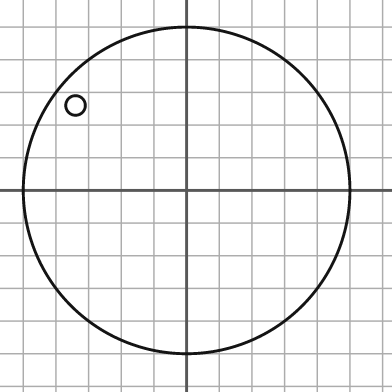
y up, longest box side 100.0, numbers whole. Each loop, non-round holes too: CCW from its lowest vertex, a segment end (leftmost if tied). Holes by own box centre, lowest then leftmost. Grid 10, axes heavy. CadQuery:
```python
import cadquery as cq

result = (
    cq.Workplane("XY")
    .moveTo(0.0, 0.0)
    .circle(50.0)
    .moveTo(-34.0, 26.0)
    .circle(3.0)
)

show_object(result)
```